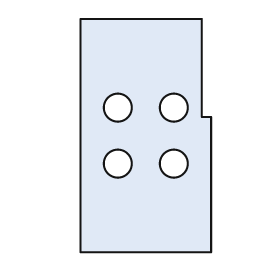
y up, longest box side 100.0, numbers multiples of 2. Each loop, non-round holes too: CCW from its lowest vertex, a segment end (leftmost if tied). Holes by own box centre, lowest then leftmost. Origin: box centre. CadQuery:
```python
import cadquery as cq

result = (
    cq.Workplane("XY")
    .moveTo(-28.0, -50.0)
    .lineTo(28.0, -50.0)
    .lineTo(28.0, 8.0)
    .lineTo(24.0, 8.0)
    .lineTo(24.0, 50.0)
    .lineTo(-28.0, 50.0)
    .close()
    .moveTo(-12.0, -12.0)
    .circle(6.0)
    .moveTo(12.0, -12.0)
    .circle(6.0)
    .moveTo(-12.0, 12.0)
    .circle(6.0)
    .moveTo(12.0, 12.0)
    .circle(6.0)
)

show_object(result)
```